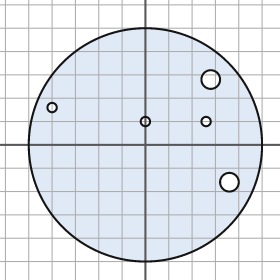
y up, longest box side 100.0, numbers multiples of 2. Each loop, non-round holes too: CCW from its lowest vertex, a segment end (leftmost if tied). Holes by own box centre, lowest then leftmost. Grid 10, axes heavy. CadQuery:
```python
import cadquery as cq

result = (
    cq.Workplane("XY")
    .moveTo(0.0, 0.0)
    .circle(50.0)
    .moveTo(36.0, -16.0)
    .circle(4.0)
    .moveTo(0.0, 10.0)
    .circle(2.0)
    .moveTo(26.0, 10.0)
    .circle(2.0)
    .moveTo(-40.0, 16.0)
    .circle(2.0)
    .moveTo(28.0, 28.0)
    .circle(4.0)
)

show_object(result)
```